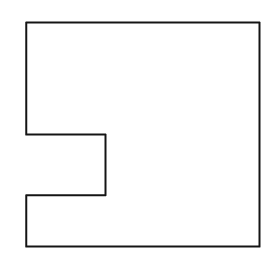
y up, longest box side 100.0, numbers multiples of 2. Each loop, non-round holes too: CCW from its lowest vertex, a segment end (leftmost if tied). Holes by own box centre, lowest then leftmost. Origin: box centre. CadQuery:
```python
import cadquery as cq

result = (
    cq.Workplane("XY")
    .moveTo(-50.0, -48.0)
    .lineTo(50.0, -48.0)
    .lineTo(50.0, 48.0)
    .lineTo(-50.0, 48.0)
    .lineTo(-50.0, 0.0)
    .lineTo(-16.0, 0.0)
    .lineTo(-16.0, -26.0)
    .lineTo(-50.0, -26.0)
    .close()
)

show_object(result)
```